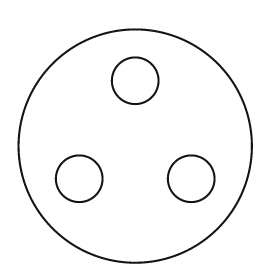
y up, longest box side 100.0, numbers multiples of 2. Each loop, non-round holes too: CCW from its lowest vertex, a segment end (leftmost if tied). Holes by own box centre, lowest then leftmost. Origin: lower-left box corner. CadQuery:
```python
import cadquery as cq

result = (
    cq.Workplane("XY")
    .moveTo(50.0, 50.0)
    .circle(50.0)
    .moveTo(26.0, 36.0)
    .circle(10.0)
    .moveTo(74.0, 36.0)
    .circle(10.0)
    .moveTo(50.0, 78.0)
    .circle(10.0)
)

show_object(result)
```